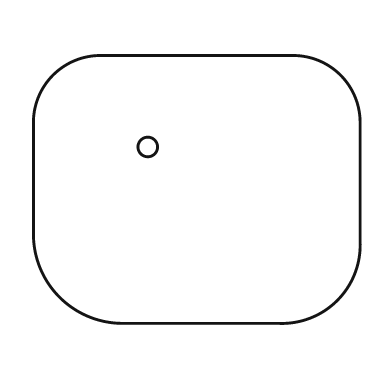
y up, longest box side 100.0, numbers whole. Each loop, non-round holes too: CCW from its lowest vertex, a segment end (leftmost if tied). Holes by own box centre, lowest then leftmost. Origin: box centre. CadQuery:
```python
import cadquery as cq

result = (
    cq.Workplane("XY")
    .moveTo(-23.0, -41.0)
    .lineTo(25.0, -41.0)
    .threePointArc((43.0, -34.0), (50.0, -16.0))
    .lineTo(50.0, 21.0)
    .threePointArc((44.0, 35.0), (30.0, 41.0))
    .lineTo(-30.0, 41.0)
    .threePointArc((-44.0, 35.0), (-50.0, 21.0))
    .lineTo(-50.0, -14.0)
    .threePointArc((-42.0, -33.0), (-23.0, -41.0))
    .close()
    .moveTo(-15.0, 13.0)
    .circle(3.0)
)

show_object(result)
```